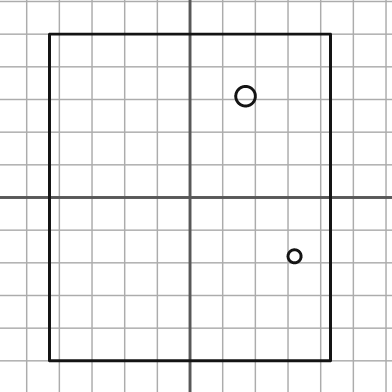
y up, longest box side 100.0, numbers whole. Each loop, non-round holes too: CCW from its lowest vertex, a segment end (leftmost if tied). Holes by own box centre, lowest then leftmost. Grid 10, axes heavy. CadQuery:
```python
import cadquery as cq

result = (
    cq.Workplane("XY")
    .moveTo(-43.0, -50.0)
    .lineTo(43.0, -50.0)
    .lineTo(43.0, 50.0)
    .lineTo(-43.0, 50.0)
    .close()
    .moveTo(32.0, -18.0)
    .circle(2.0)
    .moveTo(17.0, 31.0)
    .circle(3.0)
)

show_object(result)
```